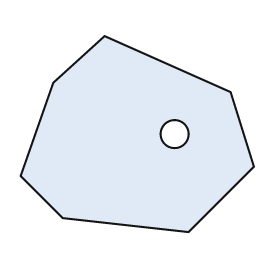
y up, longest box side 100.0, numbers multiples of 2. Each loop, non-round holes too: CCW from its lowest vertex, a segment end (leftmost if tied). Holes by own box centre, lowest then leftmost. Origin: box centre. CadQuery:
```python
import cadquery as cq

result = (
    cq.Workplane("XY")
    .moveTo(22.0, -42.0)
    .lineTo(50.0, -14.0)
    .lineTo(40.0, 18.0)
    .lineTo(-14.0, 42.0)
    .lineTo(-36.0, 22.0)
    .lineTo(-50.0, -18.0)
    .lineTo(-32.0, -36.0)
    .close()
    .moveTo(16.0, 0.0)
    .circle(6.0)
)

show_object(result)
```